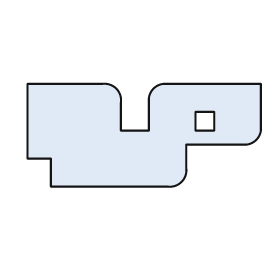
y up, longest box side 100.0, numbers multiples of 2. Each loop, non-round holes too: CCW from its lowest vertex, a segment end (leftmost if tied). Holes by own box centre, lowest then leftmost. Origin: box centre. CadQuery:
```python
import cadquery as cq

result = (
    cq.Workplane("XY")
    .moveTo(-40.0, -22.0)
    .lineTo(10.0, -22.0)
    .threePointArc((16.0, -20.0), (18.0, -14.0))
    .lineTo(18.0, -4.0)
    .lineTo(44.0, -4.0)
    .threePointArc((48.0, -2.0), (50.0, 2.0))
    .lineTo(50.0, 22.0)
    .lineTo(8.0, 22.0)
    .threePointArc((4.0, 20.0), (2.0, 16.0))
    .lineTo(2.0, 2.0)
    .lineTo(-10.0, 2.0)
    .lineTo(-10.0, 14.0)
    .threePointArc((-12.0, 20.0), (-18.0, 22.0))
    .lineTo(-50.0, 22.0)
    .lineTo(-50.0, -10.0)
    .lineTo(-40.0, -10.0)
    .close()
    .moveTo(22.0, 2.0)
    .lineTo(30.0, 2.0)
    .lineTo(30.0, 10.0)
    .lineTo(22.0, 10.0)
    .close()
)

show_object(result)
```